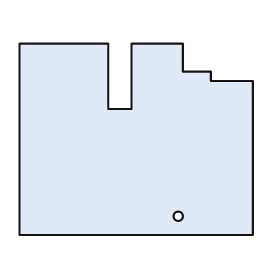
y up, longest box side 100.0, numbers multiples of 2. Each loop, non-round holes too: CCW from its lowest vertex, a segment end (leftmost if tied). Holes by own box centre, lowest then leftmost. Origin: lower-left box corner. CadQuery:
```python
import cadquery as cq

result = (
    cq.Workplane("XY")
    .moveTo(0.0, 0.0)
    .lineTo(100.0, 0.0)
    .lineTo(100.0, 66.0)
    .lineTo(82.0, 66.0)
    .lineTo(82.0, 70.0)
    .lineTo(70.0, 70.0)
    .lineTo(70.0, 82.0)
    .lineTo(48.0, 82.0)
    .lineTo(48.0, 54.0)
    .lineTo(38.0, 54.0)
    .lineTo(38.0, 82.0)
    .lineTo(0.0, 82.0)
    .close()
    .moveTo(68.0, 8.0)
    .circle(2.0)
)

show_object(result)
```